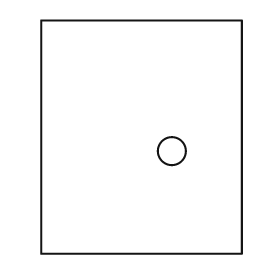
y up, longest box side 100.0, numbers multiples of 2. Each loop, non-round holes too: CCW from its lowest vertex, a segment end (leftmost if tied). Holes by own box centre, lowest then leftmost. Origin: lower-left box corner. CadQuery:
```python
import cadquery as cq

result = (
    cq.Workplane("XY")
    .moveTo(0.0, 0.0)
    .lineTo(86.0, 0.0)
    .lineTo(86.0, 100.0)
    .lineTo(0.0, 100.0)
    .close()
    .moveTo(56.0, 44.0)
    .circle(6.0)
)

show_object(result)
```